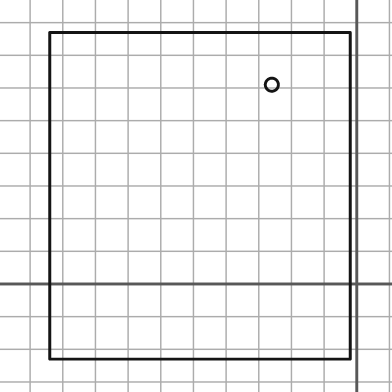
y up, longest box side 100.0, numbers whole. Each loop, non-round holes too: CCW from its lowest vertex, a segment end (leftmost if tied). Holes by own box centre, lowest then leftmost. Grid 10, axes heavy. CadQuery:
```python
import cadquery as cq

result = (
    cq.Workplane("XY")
    .moveTo(-94.0, -23.0)
    .lineTo(-2.0, -23.0)
    .lineTo(-2.0, 77.0)
    .lineTo(-94.0, 77.0)
    .close()
    .moveTo(-26.0, 61.0)
    .circle(2.0)
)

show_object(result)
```